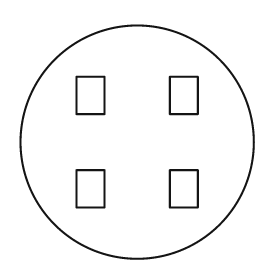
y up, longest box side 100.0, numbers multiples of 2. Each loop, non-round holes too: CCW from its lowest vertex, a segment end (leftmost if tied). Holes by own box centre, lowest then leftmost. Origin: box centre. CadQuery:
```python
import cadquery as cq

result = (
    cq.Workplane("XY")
    .moveTo(0.0, 0.0)
    .circle(50.0)
    .moveTo(-26.0, -28.0)
    .lineTo(-14.0, -28.0)
    .lineTo(-14.0, -12.0)
    .lineTo(-26.0, -12.0)
    .close()
    .moveTo(14.0, -28.0)
    .lineTo(26.0, -28.0)
    .lineTo(26.0, -12.0)
    .lineTo(14.0, -12.0)
    .close()
    .moveTo(-26.0, 12.0)
    .lineTo(-14.0, 12.0)
    .lineTo(-14.0, 28.0)
    .lineTo(-26.0, 28.0)
    .close()
    .moveTo(14.0, 12.0)
    .lineTo(26.0, 12.0)
    .lineTo(26.0, 28.0)
    .lineTo(14.0, 28.0)
    .close()
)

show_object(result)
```